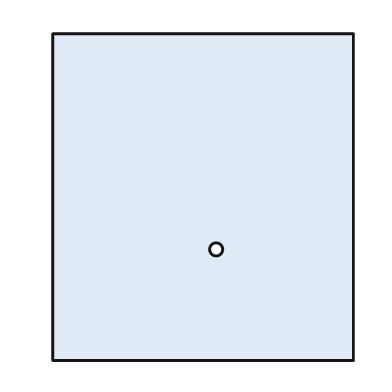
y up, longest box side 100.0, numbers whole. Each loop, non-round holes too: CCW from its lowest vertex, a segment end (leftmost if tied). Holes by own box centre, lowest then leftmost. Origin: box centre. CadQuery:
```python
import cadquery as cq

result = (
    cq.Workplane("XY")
    .moveTo(-46.0, -50.0)
    .lineTo(46.0, -50.0)
    .lineTo(46.0, 50.0)
    .lineTo(-46.0, 50.0)
    .close()
    .moveTo(4.0, -16.0)
    .circle(2.0)
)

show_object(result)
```